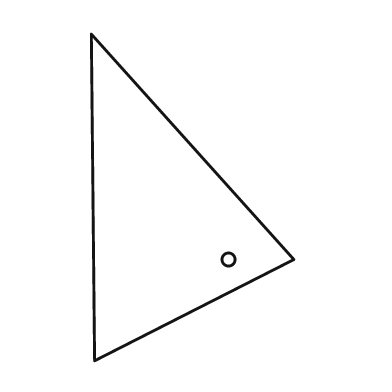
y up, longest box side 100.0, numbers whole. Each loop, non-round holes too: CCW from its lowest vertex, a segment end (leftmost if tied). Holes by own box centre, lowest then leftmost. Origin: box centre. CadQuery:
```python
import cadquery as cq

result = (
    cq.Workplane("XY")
    .moveTo(-30.0, -50.0)
    .lineTo(31.0, -19.0)
    .lineTo(-31.0, 50.0)
    .close()
    .moveTo(11.0, -19.0)
    .circle(2.0)
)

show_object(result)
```